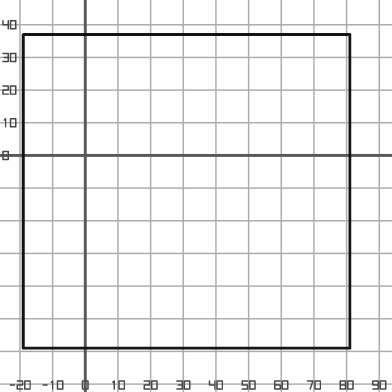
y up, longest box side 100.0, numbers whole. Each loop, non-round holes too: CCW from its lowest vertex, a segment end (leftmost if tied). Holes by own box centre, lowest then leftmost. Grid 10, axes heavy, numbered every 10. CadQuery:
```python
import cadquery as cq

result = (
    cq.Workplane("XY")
    .moveTo(-19.0, -59.0)
    .lineTo(81.0, -59.0)
    .lineTo(81.0, 37.0)
    .lineTo(-19.0, 37.0)
    .close()
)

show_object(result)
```